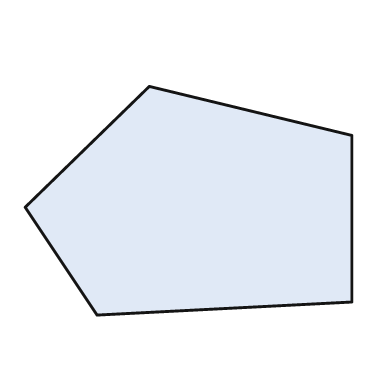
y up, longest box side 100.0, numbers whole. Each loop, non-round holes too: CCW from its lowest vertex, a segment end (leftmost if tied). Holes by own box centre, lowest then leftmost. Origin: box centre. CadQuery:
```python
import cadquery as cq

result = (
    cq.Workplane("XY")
    .moveTo(-28.0, -35.0)
    .lineTo(50.0, -31.0)
    .lineTo(50.0, 20.0)
    .lineTo(-12.0, 35.0)
    .lineTo(-50.0, -2.0)
    .close()
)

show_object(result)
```